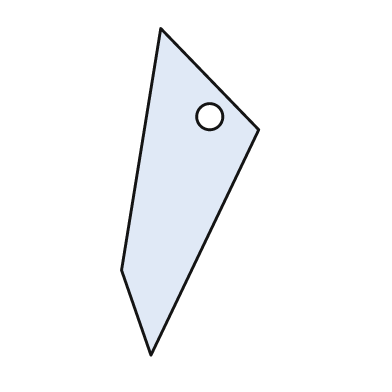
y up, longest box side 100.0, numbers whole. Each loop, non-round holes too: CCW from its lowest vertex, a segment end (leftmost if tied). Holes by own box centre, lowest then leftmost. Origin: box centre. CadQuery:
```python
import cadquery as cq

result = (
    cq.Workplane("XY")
    .moveTo(-12.0, -50.0)
    .lineTo(21.0, 19.0)
    .lineTo(-9.0, 50.0)
    .lineTo(-21.0, -24.0)
    .close()
    .moveTo(6.0, 23.0)
    .circle(4.0)
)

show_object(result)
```